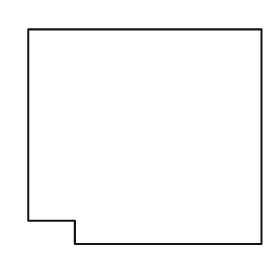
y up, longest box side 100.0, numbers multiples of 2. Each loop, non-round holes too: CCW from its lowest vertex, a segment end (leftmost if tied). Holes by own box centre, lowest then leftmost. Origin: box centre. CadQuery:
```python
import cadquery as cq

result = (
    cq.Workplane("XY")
    .moveTo(-30.0, -46.0)
    .lineTo(50.0, -46.0)
    .lineTo(50.0, 46.0)
    .lineTo(-50.0, 46.0)
    .lineTo(-50.0, -36.0)
    .lineTo(-30.0, -36.0)
    .close()
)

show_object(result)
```